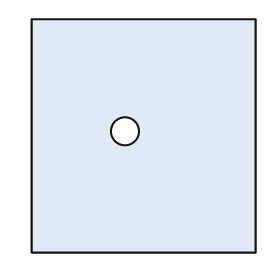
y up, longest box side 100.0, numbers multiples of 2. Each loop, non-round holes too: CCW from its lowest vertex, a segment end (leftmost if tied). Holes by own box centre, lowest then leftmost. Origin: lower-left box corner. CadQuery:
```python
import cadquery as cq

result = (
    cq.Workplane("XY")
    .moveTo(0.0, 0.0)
    .lineTo(96.0, 0.0)
    .lineTo(96.0, 100.0)
    .lineTo(0.0, 100.0)
    .close()
    .moveTo(40.0, 52.0)
    .circle(6.0)
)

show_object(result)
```